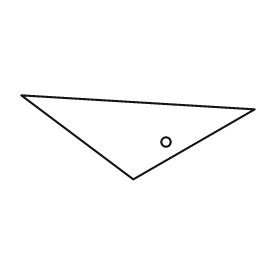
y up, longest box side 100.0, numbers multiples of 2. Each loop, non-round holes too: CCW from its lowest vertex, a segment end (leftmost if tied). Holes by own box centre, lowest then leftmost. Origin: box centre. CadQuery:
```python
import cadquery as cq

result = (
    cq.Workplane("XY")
    .moveTo(-2.0, -18.0)
    .lineTo(50.0, 12.0)
    .lineTo(-50.0, 18.0)
    .close()
    .moveTo(12.0, -2.0)
    .circle(2.0)
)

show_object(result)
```